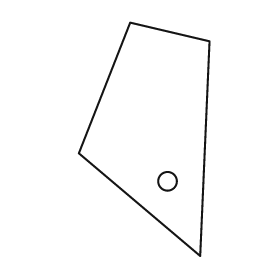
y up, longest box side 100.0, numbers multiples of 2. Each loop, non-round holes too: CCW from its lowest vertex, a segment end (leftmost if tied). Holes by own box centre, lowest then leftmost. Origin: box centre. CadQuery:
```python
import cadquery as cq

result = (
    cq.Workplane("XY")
    .moveTo(24.0, -50.0)
    .lineTo(28.0, 42.0)
    .lineTo(-6.0, 50.0)
    .lineTo(-28.0, -6.0)
    .close()
    .moveTo(10.0, -18.0)
    .circle(4.0)
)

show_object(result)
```